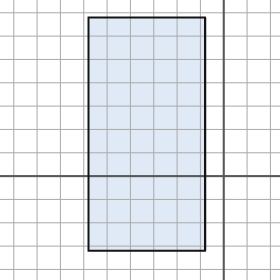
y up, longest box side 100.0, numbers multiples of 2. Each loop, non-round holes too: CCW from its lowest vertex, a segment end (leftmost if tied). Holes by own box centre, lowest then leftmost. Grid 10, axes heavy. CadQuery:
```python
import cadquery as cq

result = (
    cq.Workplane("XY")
    .moveTo(-58.0, -32.0)
    .lineTo(-8.0, -32.0)
    .lineTo(-8.0, 68.0)
    .lineTo(-58.0, 68.0)
    .close()
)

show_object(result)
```